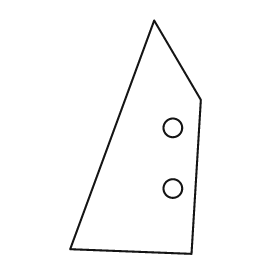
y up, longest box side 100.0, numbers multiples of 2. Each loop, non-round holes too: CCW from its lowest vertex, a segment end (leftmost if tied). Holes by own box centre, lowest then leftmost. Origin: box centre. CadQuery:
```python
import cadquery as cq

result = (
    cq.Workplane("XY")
    .moveTo(24.0, -50.0)
    .lineTo(28.0, 16.0)
    .lineTo(8.0, 50.0)
    .lineTo(-28.0, -48.0)
    .close()
    .moveTo(16.0, -22.0)
    .circle(4.0)
    .moveTo(16.0, 4.0)
    .circle(4.0)
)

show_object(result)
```